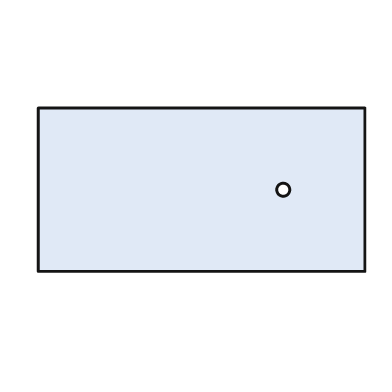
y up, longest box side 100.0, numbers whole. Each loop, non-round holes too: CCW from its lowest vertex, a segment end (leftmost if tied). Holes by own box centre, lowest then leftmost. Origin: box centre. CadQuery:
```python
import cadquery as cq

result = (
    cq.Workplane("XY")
    .moveTo(-50.0, -25.0)
    .lineTo(50.0, -25.0)
    .lineTo(50.0, 25.0)
    .lineTo(-50.0, 25.0)
    .close()
    .moveTo(25.0, 0.0)
    .circle(2.0)
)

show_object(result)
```